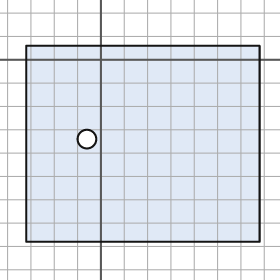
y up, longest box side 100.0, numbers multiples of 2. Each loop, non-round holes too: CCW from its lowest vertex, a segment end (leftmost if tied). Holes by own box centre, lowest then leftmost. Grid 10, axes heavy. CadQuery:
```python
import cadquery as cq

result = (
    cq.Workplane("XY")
    .moveTo(-32.0, -78.0)
    .lineTo(68.0, -78.0)
    .lineTo(68.0, 6.0)
    .lineTo(-32.0, 6.0)
    .close()
    .moveTo(-6.0, -34.0)
    .circle(4.0)
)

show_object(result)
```